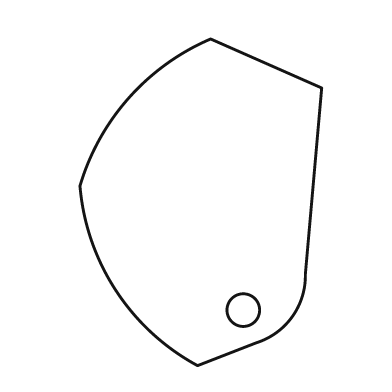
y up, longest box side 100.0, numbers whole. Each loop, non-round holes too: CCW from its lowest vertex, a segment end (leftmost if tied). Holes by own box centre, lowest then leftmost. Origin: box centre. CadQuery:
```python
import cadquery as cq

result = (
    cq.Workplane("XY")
    .moveTo(-1.0, -50.0)
    .lineTo(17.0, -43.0)
    .threePointArc((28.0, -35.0), (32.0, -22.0))
    .lineTo(37.0, 35.0)
    .lineTo(3.0, 50.0)
    .threePointArc((-22.0, 32.0), (-37.0, 5.0))
    .threePointArc((-26.0, -27.0), (-1.0, -50.0))
    .close()
    .moveTo(13.0, -33.0)
    .circle(5.0)
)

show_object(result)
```